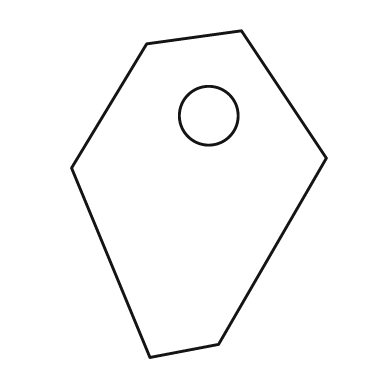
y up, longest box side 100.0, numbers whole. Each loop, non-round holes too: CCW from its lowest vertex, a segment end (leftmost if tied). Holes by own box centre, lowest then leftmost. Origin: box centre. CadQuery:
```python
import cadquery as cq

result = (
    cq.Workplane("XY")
    .moveTo(-15.0, -50.0)
    .lineTo(6.0, -46.0)
    .lineTo(39.0, 11.0)
    .lineTo(13.0, 50.0)
    .lineTo(-16.0, 46.0)
    .lineTo(-39.0, 8.0)
    .close()
    .moveTo(3.0, 24.0)
    .circle(9.0)
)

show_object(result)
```